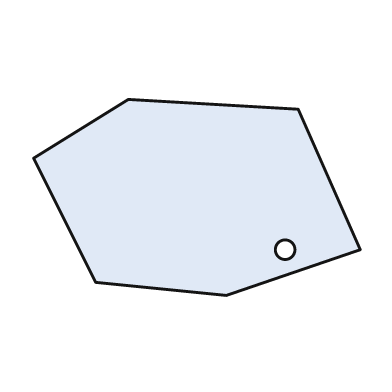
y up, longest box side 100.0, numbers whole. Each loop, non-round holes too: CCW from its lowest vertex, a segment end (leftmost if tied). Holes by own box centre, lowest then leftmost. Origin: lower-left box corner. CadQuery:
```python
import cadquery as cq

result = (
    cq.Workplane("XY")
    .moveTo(59.0, 0.0)
    .lineTo(100.0, 14.0)
    .lineTo(81.0, 57.0)
    .lineTo(29.0, 60.0)
    .lineTo(0.0, 42.0)
    .lineTo(19.0, 4.0)
    .close()
    .moveTo(77.0, 14.0)
    .circle(3.0)
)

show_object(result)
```